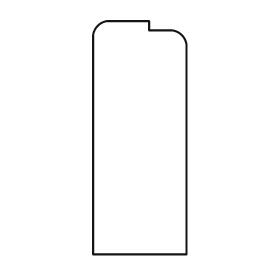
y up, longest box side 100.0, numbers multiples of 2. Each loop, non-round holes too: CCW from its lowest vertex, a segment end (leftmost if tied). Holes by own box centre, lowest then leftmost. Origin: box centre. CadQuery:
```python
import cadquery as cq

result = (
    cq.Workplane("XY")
    .moveTo(-20.0, -50.0)
    .lineTo(20.0, -50.0)
    .lineTo(20.0, 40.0)
    .threePointArc((18.0, 44.0), (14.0, 46.0))
    .lineTo(4.0, 46.0)
    .lineTo(4.0, 50.0)
    .lineTo(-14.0, 50.0)
    .threePointArc((-18.0, 48.0), (-20.0, 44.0))
    .close()
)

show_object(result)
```